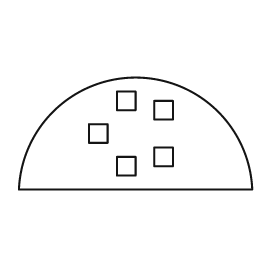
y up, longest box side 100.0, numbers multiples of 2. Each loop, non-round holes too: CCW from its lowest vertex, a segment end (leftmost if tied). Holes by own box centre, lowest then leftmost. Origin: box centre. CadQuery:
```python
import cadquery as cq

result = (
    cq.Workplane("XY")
    .moveTo(-50.0, -24.0)
    .lineTo(50.0, -24.0)
    .threePointArc((0.0, 24.0), (-50.0, -24.0))
    .close()
    .moveTo(-8.0, -18.0)
    .lineTo(0.0, -18.0)
    .lineTo(0.0, -10.0)
    .lineTo(-8.0, -10.0)
    .close()
    .moveTo(8.0, -14.0)
    .lineTo(16.0, -14.0)
    .lineTo(16.0, -6.0)
    .lineTo(8.0, -6.0)
    .close()
    .moveTo(-20.0, -4.0)
    .lineTo(-12.0, -4.0)
    .lineTo(-12.0, 4.0)
    .lineTo(-20.0, 4.0)
    .close()
    .moveTo(8.0, 6.0)
    .lineTo(16.0, 6.0)
    .lineTo(16.0, 14.0)
    .lineTo(8.0, 14.0)
    .close()
    .moveTo(-8.0, 10.0)
    .lineTo(0.0, 10.0)
    .lineTo(0.0, 18.0)
    .lineTo(-8.0, 18.0)
    .close()
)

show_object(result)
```